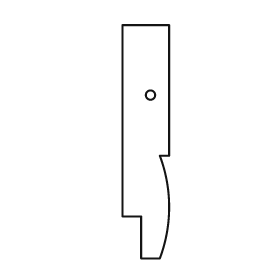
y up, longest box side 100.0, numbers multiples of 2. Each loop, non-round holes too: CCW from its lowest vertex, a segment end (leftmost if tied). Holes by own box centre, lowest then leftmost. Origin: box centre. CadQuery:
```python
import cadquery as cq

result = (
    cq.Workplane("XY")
    .moveTo(-2.0, -50.0)
    .lineTo(6.0, -50.0)
    .threePointArc((10.0, -28.0), (6.0, -6.0))
    .lineTo(10.0, -6.0)
    .lineTo(10.0, 50.0)
    .lineTo(-10.0, 50.0)
    .lineTo(-10.0, -32.0)
    .lineTo(-2.0, -32.0)
    .close()
    .moveTo(2.0, 20.0)
    .circle(2.0)
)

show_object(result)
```